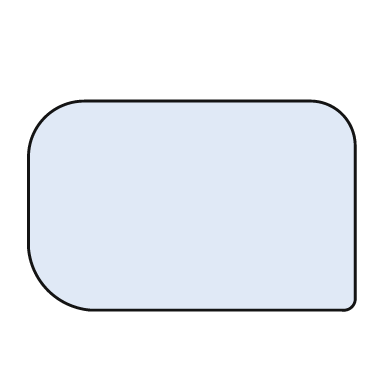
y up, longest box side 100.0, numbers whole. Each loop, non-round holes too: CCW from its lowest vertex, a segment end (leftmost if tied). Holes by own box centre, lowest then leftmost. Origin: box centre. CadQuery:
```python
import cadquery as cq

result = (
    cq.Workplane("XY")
    .moveTo(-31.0, -32.0)
    .lineTo(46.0, -32.0)
    .threePointArc((49.0, -31.0), (50.0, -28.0))
    .lineTo(50.0, 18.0)
    .threePointArc((46.0, 28.0), (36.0, 32.0))
    .lineTo(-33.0, 32.0)
    .threePointArc((-45.0, 27.0), (-50.0, 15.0))
    .lineTo(-50.0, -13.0)
    .threePointArc((-44.0, -26.0), (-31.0, -32.0))
    .close()
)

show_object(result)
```